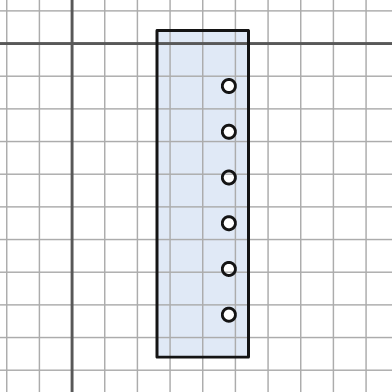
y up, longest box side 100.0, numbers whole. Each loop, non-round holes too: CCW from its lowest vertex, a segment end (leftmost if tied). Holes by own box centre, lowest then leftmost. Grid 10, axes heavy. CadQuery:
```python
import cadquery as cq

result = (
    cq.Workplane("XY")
    .moveTo(26.0, -96.0)
    .lineTo(54.0, -96.0)
    .lineTo(54.0, 4.0)
    .lineTo(26.0, 4.0)
    .close()
    .moveTo(48.0, -83.0)
    .circle(2.0)
    .moveTo(48.0, -69.0)
    .circle(2.0)
    .moveTo(48.0, -55.0)
    .circle(2.0)
    .moveTo(48.0, -41.0)
    .circle(2.0)
    .moveTo(48.0, -27.0)
    .circle(2.0)
    .moveTo(48.0, -13.0)
    .circle(2.0)
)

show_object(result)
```